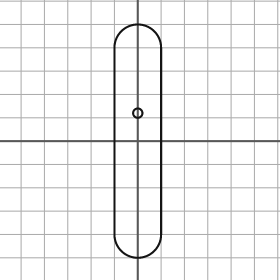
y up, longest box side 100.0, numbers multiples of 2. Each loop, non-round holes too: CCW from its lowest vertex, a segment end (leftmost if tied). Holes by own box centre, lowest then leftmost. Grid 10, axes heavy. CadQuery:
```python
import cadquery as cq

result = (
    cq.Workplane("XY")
    .moveTo(-10.0, -40.0)
    .threePointArc((0.0, -50.0), (10.0, -40.0))
    .lineTo(10.0, 40.0)
    .threePointArc((0.0, 50.0), (-10.0, 40.0))
    .close()
    .moveTo(0.0, 12.0)
    .circle(2.0)
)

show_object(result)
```